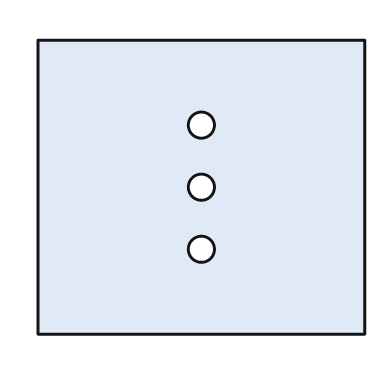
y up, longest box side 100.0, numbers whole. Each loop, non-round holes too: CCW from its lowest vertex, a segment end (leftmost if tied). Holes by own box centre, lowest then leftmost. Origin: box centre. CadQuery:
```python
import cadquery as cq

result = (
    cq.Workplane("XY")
    .moveTo(-50.0, -45.0)
    .lineTo(50.0, -45.0)
    .lineTo(50.0, 45.0)
    .lineTo(-50.0, 45.0)
    .close()
    .moveTo(0.0, -19.0)
    .circle(4.0)
    .moveTo(0.0, 0.0)
    .circle(4.0)
    .moveTo(0.0, 19.0)
    .circle(4.0)
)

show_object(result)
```